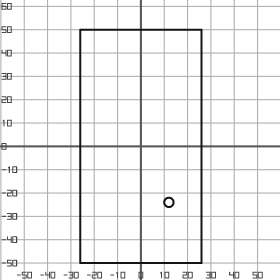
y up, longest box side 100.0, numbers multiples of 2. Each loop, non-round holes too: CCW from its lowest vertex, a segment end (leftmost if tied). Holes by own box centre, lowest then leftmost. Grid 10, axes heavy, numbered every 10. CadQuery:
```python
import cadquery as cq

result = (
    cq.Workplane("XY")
    .moveTo(-26.0, -50.0)
    .lineTo(26.0, -50.0)
    .lineTo(26.0, 50.0)
    .lineTo(-26.0, 50.0)
    .close()
    .moveTo(12.0, -24.0)
    .circle(2.0)
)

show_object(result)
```